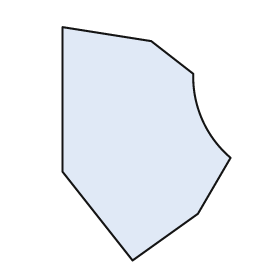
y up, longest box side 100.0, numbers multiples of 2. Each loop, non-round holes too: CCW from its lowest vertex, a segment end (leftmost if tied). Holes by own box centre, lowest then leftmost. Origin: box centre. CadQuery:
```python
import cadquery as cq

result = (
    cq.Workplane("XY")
    .moveTo(-6.0, -50.0)
    .lineTo(22.0, -30.0)
    .lineTo(36.0, -6.0)
    .threePointArc((24.0, 10.0), (20.0, 30.0))
    .lineTo(2.0, 44.0)
    .lineTo(-36.0, 50.0)
    .lineTo(-36.0, -12.0)
    .close()
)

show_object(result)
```